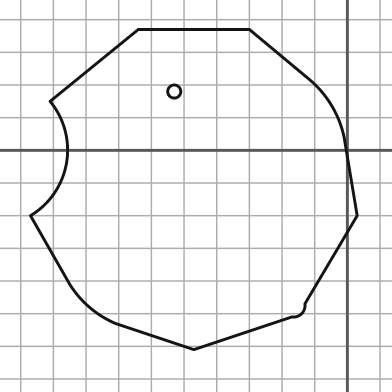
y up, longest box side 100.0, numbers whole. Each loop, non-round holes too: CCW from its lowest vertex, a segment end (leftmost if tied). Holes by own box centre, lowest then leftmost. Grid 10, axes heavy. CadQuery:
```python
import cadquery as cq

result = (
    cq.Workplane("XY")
    .moveTo(-47.0, -61.0)
    .lineTo(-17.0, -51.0)
    .threePointArc((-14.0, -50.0), (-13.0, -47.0))
    .lineTo(3.0, -20.0)
    .lineTo(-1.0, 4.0)
    .threePointArc((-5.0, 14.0), (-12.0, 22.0))
    .lineTo(-30.0, 37.0)
    .lineTo(-64.0, 37.0)
    .lineTo(-91.0, 15.0)
    .threePointArc((-86.0, -4.0), (-97.0, -20.0))
    .lineTo(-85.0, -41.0)
    .threePointArc((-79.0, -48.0), (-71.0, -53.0))
    .close()
    .moveTo(-53.0, 18.0)
    .circle(2.0)
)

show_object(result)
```